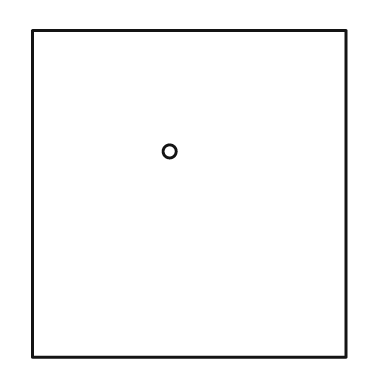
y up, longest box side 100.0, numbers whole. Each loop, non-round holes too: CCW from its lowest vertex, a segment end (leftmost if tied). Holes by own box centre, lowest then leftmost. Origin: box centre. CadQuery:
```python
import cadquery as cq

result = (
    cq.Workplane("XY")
    .moveTo(-48.0, -50.0)
    .lineTo(48.0, -50.0)
    .lineTo(48.0, 50.0)
    .lineTo(-48.0, 50.0)
    .close()
    .moveTo(-6.0, 13.0)
    .circle(2.0)
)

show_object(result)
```